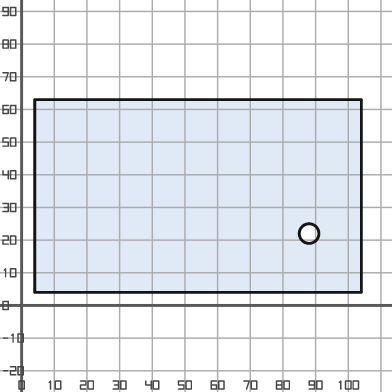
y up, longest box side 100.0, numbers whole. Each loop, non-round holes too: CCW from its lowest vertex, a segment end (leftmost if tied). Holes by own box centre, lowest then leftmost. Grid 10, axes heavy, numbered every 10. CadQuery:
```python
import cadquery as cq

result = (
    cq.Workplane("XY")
    .moveTo(4.0, 4.0)
    .lineTo(104.0, 4.0)
    .lineTo(104.0, 63.0)
    .lineTo(4.0, 63.0)
    .close()
    .moveTo(88.0, 22.0)
    .circle(3.0)
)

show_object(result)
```